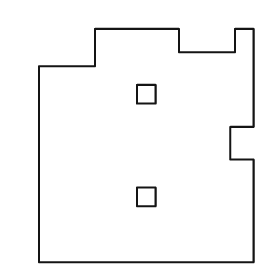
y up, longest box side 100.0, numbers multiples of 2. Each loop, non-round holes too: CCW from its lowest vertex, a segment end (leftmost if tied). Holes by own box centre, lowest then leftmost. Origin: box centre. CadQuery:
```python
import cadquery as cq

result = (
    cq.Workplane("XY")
    .moveTo(-46.0, -50.0)
    .lineTo(46.0, -50.0)
    .lineTo(46.0, -6.0)
    .lineTo(36.0, -6.0)
    .lineTo(36.0, 8.0)
    .lineTo(46.0, 8.0)
    .lineTo(46.0, 50.0)
    .lineTo(38.0, 50.0)
    .lineTo(38.0, 40.0)
    .lineTo(14.0, 40.0)
    .lineTo(14.0, 50.0)
    .lineTo(-22.0, 50.0)
    .lineTo(-22.0, 34.0)
    .lineTo(-46.0, 34.0)
    .close()
    .moveTo(-4.0, -26.0)
    .lineTo(4.0, -26.0)
    .lineTo(4.0, -18.0)
    .lineTo(-4.0, -18.0)
    .close()
    .moveTo(-4.0, 18.0)
    .lineTo(4.0, 18.0)
    .lineTo(4.0, 26.0)
    .lineTo(-4.0, 26.0)
    .close()
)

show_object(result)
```